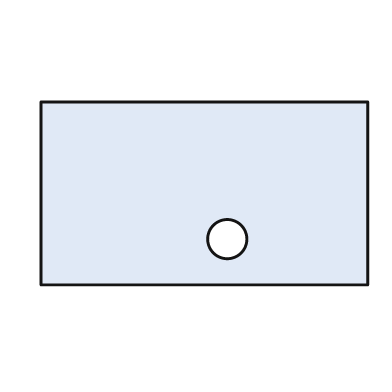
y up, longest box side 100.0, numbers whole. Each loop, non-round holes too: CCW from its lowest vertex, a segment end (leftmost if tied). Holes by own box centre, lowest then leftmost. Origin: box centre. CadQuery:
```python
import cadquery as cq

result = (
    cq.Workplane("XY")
    .moveTo(-50.0, -28.0)
    .lineTo(50.0, -28.0)
    .lineTo(50.0, 28.0)
    .lineTo(-50.0, 28.0)
    .close()
    .moveTo(7.0, -14.0)
    .circle(6.0)
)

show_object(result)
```